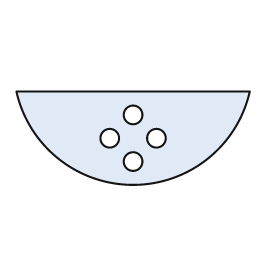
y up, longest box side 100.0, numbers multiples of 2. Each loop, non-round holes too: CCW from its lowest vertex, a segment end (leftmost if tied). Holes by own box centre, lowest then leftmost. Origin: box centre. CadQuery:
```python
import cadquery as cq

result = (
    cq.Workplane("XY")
    .moveTo(-50.0, 20.0)
    .threePointArc((0.0, -20.0), (50.0, 20.0))
    .close()
    .moveTo(0.0, -10.0)
    .circle(4.0)
    .moveTo(-10.0, 0.0)
    .circle(4.0)
    .moveTo(10.0, 0.0)
    .circle(4.0)
    .moveTo(0.0, 10.0)
    .circle(4.0)
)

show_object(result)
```